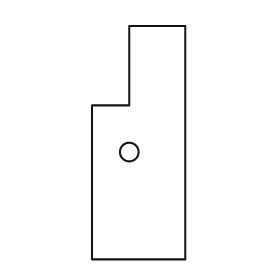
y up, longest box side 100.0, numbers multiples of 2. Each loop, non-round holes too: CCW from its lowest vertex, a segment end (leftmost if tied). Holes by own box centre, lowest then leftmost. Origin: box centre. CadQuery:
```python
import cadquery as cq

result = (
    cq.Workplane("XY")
    .moveTo(-20.0, -50.0)
    .lineTo(20.0, -50.0)
    .lineTo(20.0, 50.0)
    .lineTo(-4.0, 50.0)
    .lineTo(-4.0, 16.0)
    .lineTo(-20.0, 16.0)
    .close()
    .moveTo(-4.0, -4.0)
    .circle(4.0)
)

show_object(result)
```